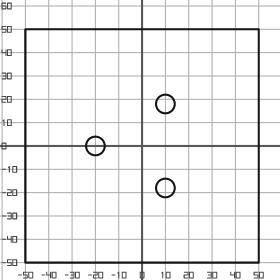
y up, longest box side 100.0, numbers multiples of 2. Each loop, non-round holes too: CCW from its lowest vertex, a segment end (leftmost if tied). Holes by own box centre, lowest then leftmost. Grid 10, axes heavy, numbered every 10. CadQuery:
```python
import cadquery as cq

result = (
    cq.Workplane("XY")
    .moveTo(-50.0, -50.0)
    .lineTo(50.0, -50.0)
    .lineTo(50.0, 50.0)
    .lineTo(-50.0, 50.0)
    .close()
    .moveTo(10.0, -18.0)
    .circle(4.0)
    .moveTo(-20.0, 0.0)
    .circle(4.0)
    .moveTo(10.0, 18.0)
    .circle(4.0)
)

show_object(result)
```